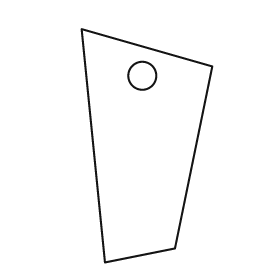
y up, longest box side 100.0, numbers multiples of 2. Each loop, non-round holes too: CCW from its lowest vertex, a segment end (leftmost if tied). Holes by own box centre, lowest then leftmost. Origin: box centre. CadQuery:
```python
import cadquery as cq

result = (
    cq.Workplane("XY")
    .moveTo(-18.0, -50.0)
    .lineTo(12.0, -44.0)
    .lineTo(28.0, 34.0)
    .lineTo(-28.0, 50.0)
    .close()
    .moveTo(-2.0, 30.0)
    .circle(6.0)
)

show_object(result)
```